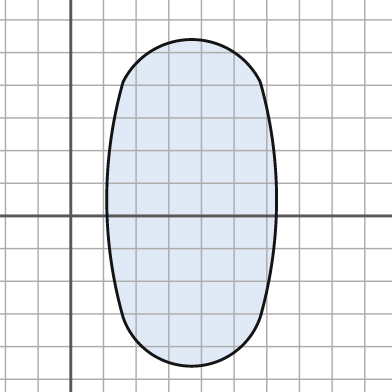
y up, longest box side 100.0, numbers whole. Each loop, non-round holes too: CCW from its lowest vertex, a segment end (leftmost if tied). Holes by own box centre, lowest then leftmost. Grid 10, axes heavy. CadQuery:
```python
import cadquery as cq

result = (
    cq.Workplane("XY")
    .moveTo(16.0, -31.0)
    .threePointArc((37.0, -46.0), (58.0, -31.0))
    .threePointArc((63.0, 5.0), (58.0, 41.0))
    .threePointArc((37.0, 54.0), (16.0, 41.0))
    .threePointArc((11.0, 5.0), (16.0, -31.0))
    .close()
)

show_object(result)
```